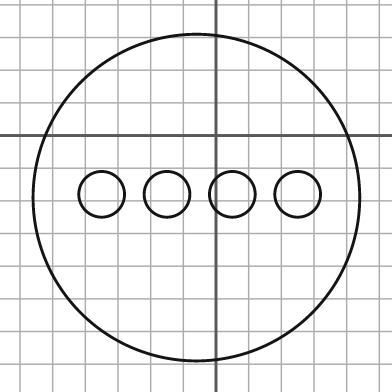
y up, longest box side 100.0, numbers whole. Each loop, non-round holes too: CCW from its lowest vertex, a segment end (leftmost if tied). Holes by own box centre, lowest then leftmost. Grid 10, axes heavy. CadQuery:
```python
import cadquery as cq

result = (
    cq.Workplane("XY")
    .moveTo(-6.0, -19.0)
    .circle(50.0)
    .moveTo(-35.0, -18.0)
    .circle(7.0)
    .moveTo(-15.0, -18.0)
    .circle(7.0)
    .moveTo(5.0, -18.0)
    .circle(7.0)
    .moveTo(25.0, -18.0)
    .circle(7.0)
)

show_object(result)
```